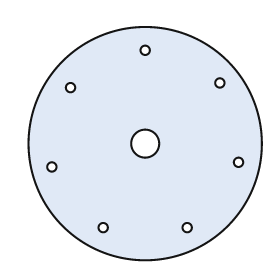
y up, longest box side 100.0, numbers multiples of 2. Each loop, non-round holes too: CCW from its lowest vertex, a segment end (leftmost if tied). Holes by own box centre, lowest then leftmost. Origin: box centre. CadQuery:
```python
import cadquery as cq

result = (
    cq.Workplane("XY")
    .moveTo(0.0, 0.0)
    .circle(50.0)
    .moveTo(-18.0, -36.0)
    .circle(2.0)
    .moveTo(18.0, -36.0)
    .circle(2.0)
    .moveTo(-40.0, -10.0)
    .circle(2.0)
    .moveTo(40.0, -8.0)
    .circle(2.0)
    .moveTo(0.0, 0.0)
    .circle(6.0)
    .moveTo(-32.0, 24.0)
    .circle(2.0)
    .moveTo(32.0, 26.0)
    .circle(2.0)
    .moveTo(0.0, 40.0)
    .circle(2.0)
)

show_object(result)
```